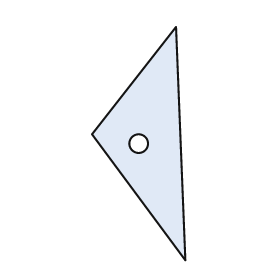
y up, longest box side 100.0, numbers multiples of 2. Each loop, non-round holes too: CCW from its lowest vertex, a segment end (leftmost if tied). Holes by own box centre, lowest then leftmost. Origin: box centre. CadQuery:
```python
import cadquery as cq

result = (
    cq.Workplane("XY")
    .moveTo(20.0, -50.0)
    .lineTo(16.0, 50.0)
    .lineTo(-20.0, 4.0)
    .close()
    .moveTo(0.0, 0.0)
    .circle(4.0)
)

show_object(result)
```